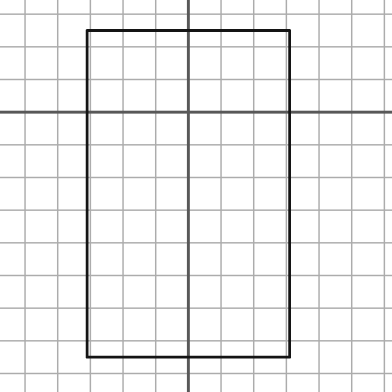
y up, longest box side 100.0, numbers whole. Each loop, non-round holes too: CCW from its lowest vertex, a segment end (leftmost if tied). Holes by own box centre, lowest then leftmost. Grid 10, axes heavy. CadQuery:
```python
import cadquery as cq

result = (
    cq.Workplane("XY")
    .moveTo(-31.0, -75.0)
    .lineTo(31.0, -75.0)
    .lineTo(31.0, 25.0)
    .lineTo(-31.0, 25.0)
    .close()
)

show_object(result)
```